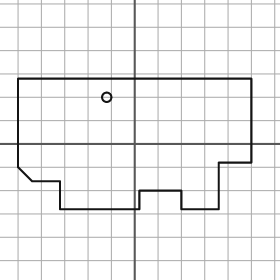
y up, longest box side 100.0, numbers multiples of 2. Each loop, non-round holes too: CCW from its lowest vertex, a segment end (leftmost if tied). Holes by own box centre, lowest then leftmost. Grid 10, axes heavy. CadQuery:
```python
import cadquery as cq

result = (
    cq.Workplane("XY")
    .moveTo(-32.0, -28.0)
    .lineTo(2.0, -28.0)
    .lineTo(2.0, -20.0)
    .lineTo(20.0, -20.0)
    .lineTo(20.0, -28.0)
    .lineTo(36.0, -28.0)
    .lineTo(36.0, -8.0)
    .lineTo(50.0, -8.0)
    .lineTo(50.0, 28.0)
    .lineTo(-50.0, 28.0)
    .lineTo(-50.0, -10.0)
    .lineTo(-44.0, -16.0)
    .lineTo(-32.0, -16.0)
    .close()
    .moveTo(-12.0, 20.0)
    .circle(2.0)
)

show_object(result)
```